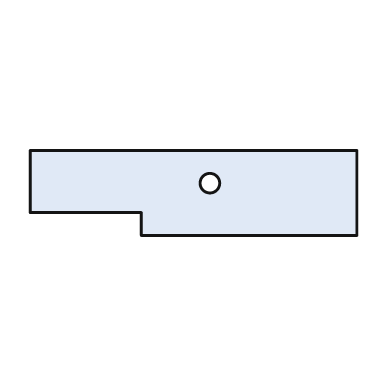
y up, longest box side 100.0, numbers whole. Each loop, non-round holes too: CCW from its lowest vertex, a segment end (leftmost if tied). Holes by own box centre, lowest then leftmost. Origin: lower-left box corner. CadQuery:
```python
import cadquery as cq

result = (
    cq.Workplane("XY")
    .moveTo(34.0, 0.0)
    .lineTo(100.0, 0.0)
    .lineTo(100.0, 26.0)
    .lineTo(0.0, 26.0)
    .lineTo(0.0, 7.0)
    .lineTo(34.0, 7.0)
    .close()
    .moveTo(55.0, 16.0)
    .circle(3.0)
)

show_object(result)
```